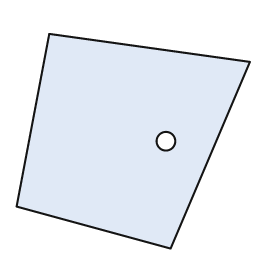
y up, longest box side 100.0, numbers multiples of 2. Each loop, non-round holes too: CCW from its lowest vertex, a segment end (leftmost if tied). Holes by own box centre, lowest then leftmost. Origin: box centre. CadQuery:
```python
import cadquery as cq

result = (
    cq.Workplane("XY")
    .moveTo(16.0, -46.0)
    .lineTo(50.0, 34.0)
    .lineTo(-36.0, 46.0)
    .lineTo(-50.0, -28.0)
    .close()
    .moveTo(14.0, 0.0)
    .circle(4.0)
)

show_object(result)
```